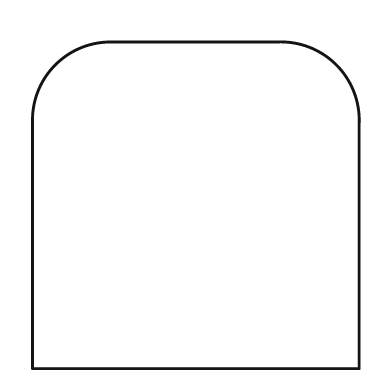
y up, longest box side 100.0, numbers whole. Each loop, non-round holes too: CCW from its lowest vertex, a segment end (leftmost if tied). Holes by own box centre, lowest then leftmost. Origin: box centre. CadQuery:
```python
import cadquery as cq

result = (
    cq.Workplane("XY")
    .moveTo(-50.0, -50.0)
    .lineTo(50.0, -50.0)
    .lineTo(50.0, 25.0)
    .threePointArc((43.0, 43.0), (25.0, 50.0))
    .lineTo(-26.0, 50.0)
    .threePointArc((-43.0, 43.0), (-50.0, 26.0))
    .close()
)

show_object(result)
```